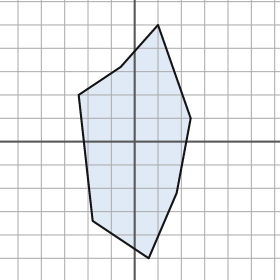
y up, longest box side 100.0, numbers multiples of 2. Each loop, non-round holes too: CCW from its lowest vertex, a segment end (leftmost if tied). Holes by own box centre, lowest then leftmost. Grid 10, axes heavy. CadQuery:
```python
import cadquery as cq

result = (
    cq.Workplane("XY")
    .moveTo(6.0, -50.0)
    .lineTo(18.0, -22.0)
    .lineTo(24.0, 10.0)
    .lineTo(10.0, 50.0)
    .lineTo(-6.0, 32.0)
    .lineTo(-24.0, 20.0)
    .lineTo(-18.0, -34.0)
    .close()
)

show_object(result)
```